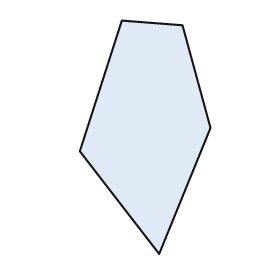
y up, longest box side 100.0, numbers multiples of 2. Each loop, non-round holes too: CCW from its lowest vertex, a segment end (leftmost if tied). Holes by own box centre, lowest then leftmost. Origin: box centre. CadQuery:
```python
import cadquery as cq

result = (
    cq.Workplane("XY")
    .moveTo(6.0, -50.0)
    .lineTo(28.0, 4.0)
    .lineTo(16.0, 48.0)
    .lineTo(-10.0, 50.0)
    .lineTo(-28.0, -6.0)
    .close()
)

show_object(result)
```